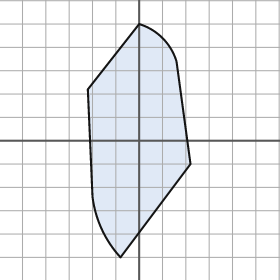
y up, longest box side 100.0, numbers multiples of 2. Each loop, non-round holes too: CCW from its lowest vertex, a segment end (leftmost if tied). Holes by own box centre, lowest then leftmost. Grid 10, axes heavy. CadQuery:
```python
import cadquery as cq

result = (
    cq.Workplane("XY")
    .moveTo(-8.0, -50.0)
    .lineTo(22.0, -10.0)
    .lineTo(16.0, 34.0)
    .threePointArc((10.0, 44.0), (0.0, 50.0))
    .lineTo(-22.0, 22.0)
    .lineTo(-20.0, -24.0)
    .threePointArc((-16.0, -38.0), (-8.0, -50.0))
    .close()
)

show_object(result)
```